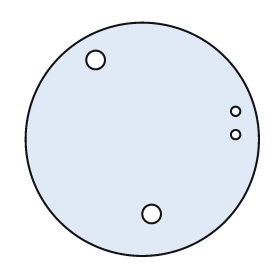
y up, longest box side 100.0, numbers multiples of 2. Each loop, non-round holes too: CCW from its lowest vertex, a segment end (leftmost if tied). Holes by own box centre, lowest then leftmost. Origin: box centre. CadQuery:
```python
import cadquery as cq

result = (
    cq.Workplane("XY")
    .moveTo(0.0, 0.0)
    .circle(50.0)
    .moveTo(4.0, -32.0)
    .circle(4.0)
    .moveTo(40.0, 2.0)
    .circle(2.0)
    .moveTo(40.0, 12.0)
    .circle(2.0)
    .moveTo(-20.0, 34.0)
    .circle(4.0)
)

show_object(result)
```